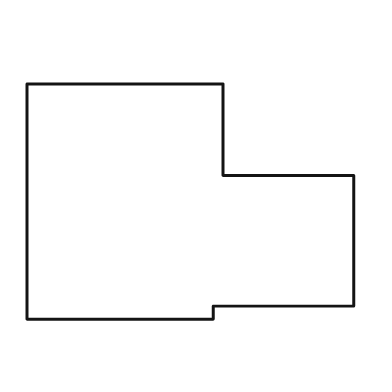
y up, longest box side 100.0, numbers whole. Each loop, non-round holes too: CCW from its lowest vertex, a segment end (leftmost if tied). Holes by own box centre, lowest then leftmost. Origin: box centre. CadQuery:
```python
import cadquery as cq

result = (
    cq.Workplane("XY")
    .moveTo(-50.0, -36.0)
    .lineTo(7.0, -36.0)
    .lineTo(7.0, -32.0)
    .lineTo(50.0, -32.0)
    .lineTo(50.0, 8.0)
    .lineTo(10.0, 8.0)
    .lineTo(10.0, 36.0)
    .lineTo(-50.0, 36.0)
    .close()
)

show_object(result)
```